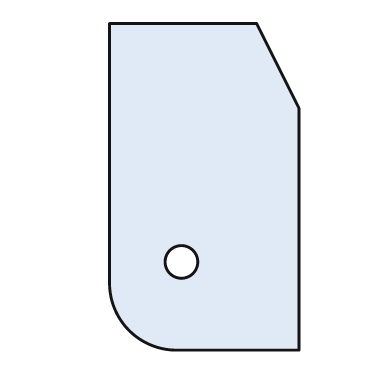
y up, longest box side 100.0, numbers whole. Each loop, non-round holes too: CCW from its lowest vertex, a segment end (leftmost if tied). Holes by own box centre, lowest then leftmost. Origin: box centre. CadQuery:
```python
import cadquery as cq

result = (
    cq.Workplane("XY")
    .moveTo(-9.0, -50.0)
    .lineTo(29.0, -50.0)
    .lineTo(29.0, 24.0)
    .lineTo(16.0, 50.0)
    .lineTo(-29.0, 50.0)
    .lineTo(-29.0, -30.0)
    .threePointArc((-23.0, -44.0), (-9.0, -50.0))
    .close()
    .moveTo(-7.0, -23.0)
    .circle(5.0)
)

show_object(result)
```